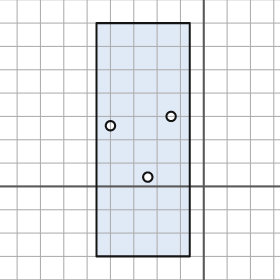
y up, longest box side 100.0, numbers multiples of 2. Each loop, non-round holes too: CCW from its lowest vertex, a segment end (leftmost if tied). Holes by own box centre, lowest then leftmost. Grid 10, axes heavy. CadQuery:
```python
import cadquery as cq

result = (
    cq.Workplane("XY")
    .moveTo(-46.0, -30.0)
    .lineTo(-6.0, -30.0)
    .lineTo(-6.0, 70.0)
    .lineTo(-46.0, 70.0)
    .close()
    .moveTo(-24.0, 4.0)
    .circle(2.0)
    .moveTo(-40.0, 26.0)
    .circle(2.0)
    .moveTo(-14.0, 30.0)
    .circle(2.0)
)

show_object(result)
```